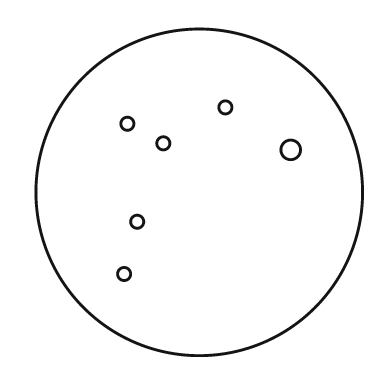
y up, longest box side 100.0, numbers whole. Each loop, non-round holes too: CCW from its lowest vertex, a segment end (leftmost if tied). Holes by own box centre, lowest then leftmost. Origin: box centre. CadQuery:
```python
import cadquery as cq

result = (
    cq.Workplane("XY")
    .moveTo(0.0, 0.0)
    .circle(50.0)
    .moveTo(-23.0, -25.0)
    .circle(2.0)
    .moveTo(-19.0, -9.0)
    .circle(2.0)
    .moveTo(28.0, 13.0)
    .circle(3.0)
    .moveTo(-11.0, 15.0)
    .circle(2.0)
    .moveTo(-22.0, 21.0)
    .circle(2.0)
    .moveTo(8.0, 26.0)
    .circle(2.0)
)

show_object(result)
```